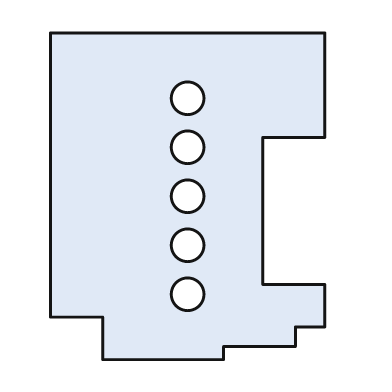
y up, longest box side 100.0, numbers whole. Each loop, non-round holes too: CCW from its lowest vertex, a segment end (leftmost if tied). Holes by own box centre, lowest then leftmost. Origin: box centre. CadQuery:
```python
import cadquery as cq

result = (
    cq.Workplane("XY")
    .moveTo(-26.0, -50.0)
    .lineTo(11.0, -50.0)
    .lineTo(11.0, -46.0)
    .lineTo(33.0, -46.0)
    .lineTo(33.0, -40.0)
    .lineTo(42.0, -40.0)
    .lineTo(42.0, -27.0)
    .lineTo(23.0, -27.0)
    .lineTo(23.0, 18.0)
    .lineTo(42.0, 18.0)
    .lineTo(42.0, 50.0)
    .lineTo(-42.0, 50.0)
    .lineTo(-42.0, -37.0)
    .lineTo(-26.0, -37.0)
    .close()
    .moveTo(0.0, -30.0)
    .circle(5.0)
    .moveTo(0.0, -15.0)
    .circle(5.0)
    .moveTo(0.0, 0.0)
    .circle(5.0)
    .moveTo(0.0, 15.0)
    .circle(5.0)
    .moveTo(0.0, 30.0)
    .circle(5.0)
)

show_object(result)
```